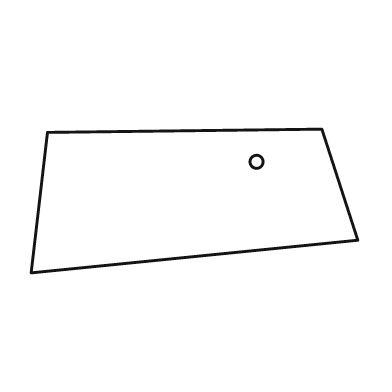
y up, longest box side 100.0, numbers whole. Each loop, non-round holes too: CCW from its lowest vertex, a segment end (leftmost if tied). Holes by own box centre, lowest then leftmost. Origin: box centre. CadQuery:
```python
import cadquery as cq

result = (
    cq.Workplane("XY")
    .moveTo(-50.0, -22.0)
    .lineTo(50.0, -12.0)
    .lineTo(39.0, 22.0)
    .lineTo(-45.0, 21.0)
    .close()
    .moveTo(19.0, 12.0)
    .circle(2.0)
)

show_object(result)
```